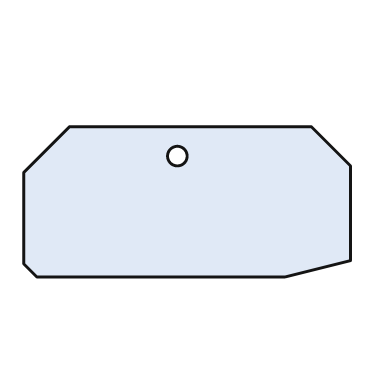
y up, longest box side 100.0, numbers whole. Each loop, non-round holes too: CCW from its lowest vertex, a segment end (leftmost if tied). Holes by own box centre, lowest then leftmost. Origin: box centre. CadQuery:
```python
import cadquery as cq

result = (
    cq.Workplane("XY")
    .moveTo(-46.0, -23.0)
    .lineTo(30.0, -23.0)
    .lineTo(50.0, -18.0)
    .lineTo(50.0, 11.0)
    .lineTo(38.0, 23.0)
    .lineTo(-36.0, 23.0)
    .lineTo(-50.0, 9.0)
    .lineTo(-50.0, -19.0)
    .close()
    .moveTo(-3.0, 14.0)
    .circle(3.0)
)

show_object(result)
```